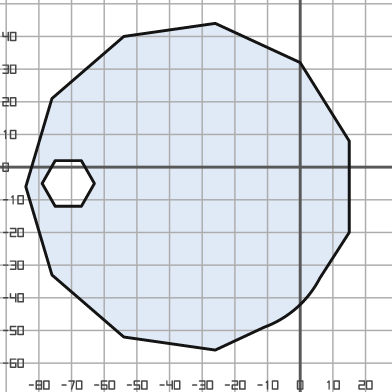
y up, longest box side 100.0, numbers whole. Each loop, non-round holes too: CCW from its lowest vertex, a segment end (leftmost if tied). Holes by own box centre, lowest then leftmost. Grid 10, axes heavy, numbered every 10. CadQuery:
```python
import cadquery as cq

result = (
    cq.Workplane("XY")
    .moveTo(-26.0, -56.0)
    .lineTo(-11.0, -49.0)
    .threePointArc((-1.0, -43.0), (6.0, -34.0))
    .lineTo(15.0, -20.0)
    .lineTo(15.0, 8.0)
    .lineTo(0.0, 32.0)
    .lineTo(-26.0, 44.0)
    .lineTo(-54.0, 40.0)
    .lineTo(-76.0, 21.0)
    .lineTo(-84.0, -6.0)
    .lineTo(-76.0, -33.0)
    .lineTo(-54.0, -52.0)
    .close()
    .moveTo(-75.0, -12.0)
    .lineTo(-67.0, -12.0)
    .lineTo(-63.0, -5.0)
    .lineTo(-67.0, 2.0)
    .lineTo(-75.0, 2.0)
    .lineTo(-79.0, -5.0)
    .close()
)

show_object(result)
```